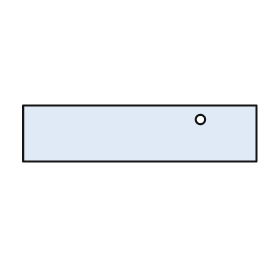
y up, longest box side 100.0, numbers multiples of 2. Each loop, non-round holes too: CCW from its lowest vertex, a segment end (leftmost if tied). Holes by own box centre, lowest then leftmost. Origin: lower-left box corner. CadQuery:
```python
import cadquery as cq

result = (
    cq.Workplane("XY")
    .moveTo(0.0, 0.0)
    .lineTo(100.0, 0.0)
    .lineTo(100.0, 24.0)
    .lineTo(0.0, 24.0)
    .close()
    .moveTo(76.0, 18.0)
    .circle(2.0)
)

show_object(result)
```